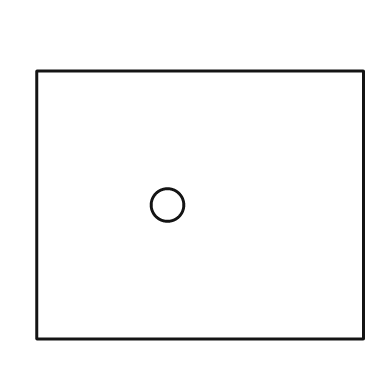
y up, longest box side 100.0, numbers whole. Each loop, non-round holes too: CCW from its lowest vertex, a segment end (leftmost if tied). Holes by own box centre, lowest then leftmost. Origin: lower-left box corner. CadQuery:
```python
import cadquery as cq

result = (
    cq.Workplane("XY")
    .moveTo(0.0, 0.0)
    .lineTo(100.0, 0.0)
    .lineTo(100.0, 82.0)
    .lineTo(0.0, 82.0)
    .close()
    .moveTo(40.0, 41.0)
    .circle(5.0)
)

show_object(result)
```